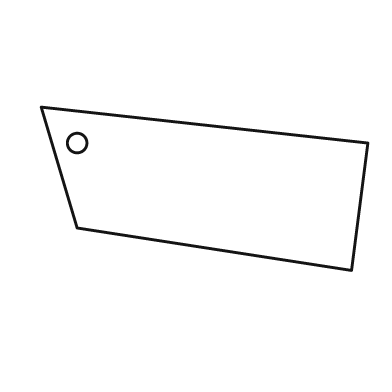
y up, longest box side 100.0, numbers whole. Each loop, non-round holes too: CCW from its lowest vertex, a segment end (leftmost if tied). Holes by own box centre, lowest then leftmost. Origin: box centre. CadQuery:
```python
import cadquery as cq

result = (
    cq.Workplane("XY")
    .moveTo(45.0, -25.0)
    .lineTo(50.0, 14.0)
    .lineTo(-50.0, 25.0)
    .lineTo(-39.0, -12.0)
    .close()
    .moveTo(-39.0, 14.0)
    .circle(3.0)
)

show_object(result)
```